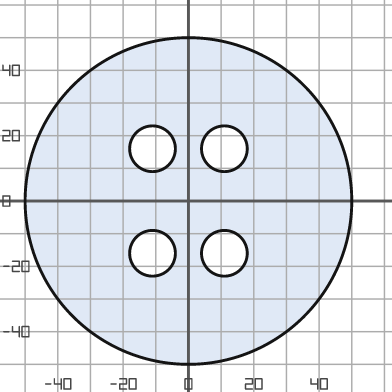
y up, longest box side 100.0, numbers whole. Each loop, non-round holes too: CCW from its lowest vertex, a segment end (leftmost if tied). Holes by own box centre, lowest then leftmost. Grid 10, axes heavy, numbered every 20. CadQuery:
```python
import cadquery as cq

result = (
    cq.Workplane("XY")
    .moveTo(0.0, 0.0)
    .circle(50.0)
    .moveTo(-11.0, -16.0)
    .circle(7.0)
    .moveTo(11.0, -16.0)
    .circle(7.0)
    .moveTo(-11.0, 16.0)
    .circle(7.0)
    .moveTo(11.0, 16.0)
    .circle(7.0)
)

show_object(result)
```